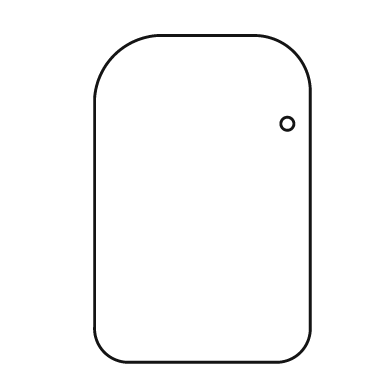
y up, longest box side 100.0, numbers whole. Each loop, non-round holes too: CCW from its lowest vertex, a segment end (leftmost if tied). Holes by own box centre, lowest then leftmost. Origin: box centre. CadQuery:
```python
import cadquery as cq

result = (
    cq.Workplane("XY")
    .moveTo(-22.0, -50.0)
    .lineTo(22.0, -50.0)
    .threePointArc((30.0, -47.0), (33.0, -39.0))
    .lineTo(33.0, 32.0)
    .threePointArc((28.0, 45.0), (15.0, 50.0))
    .lineTo(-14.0, 50.0)
    .threePointArc((-27.0, 44.0), (-33.0, 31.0))
    .lineTo(-33.0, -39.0)
    .threePointArc((-30.0, -47.0), (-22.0, -50.0))
    .close()
    .moveTo(26.0, 23.0)
    .circle(2.0)
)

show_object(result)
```